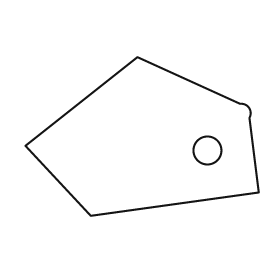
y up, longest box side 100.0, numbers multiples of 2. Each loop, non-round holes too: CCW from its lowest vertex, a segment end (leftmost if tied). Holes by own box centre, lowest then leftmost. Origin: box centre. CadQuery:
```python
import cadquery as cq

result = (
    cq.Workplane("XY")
    .moveTo(-22.0, -34.0)
    .lineTo(50.0, -24.0)
    .lineTo(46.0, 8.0)
    .threePointArc((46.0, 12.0), (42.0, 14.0))
    .lineTo(-2.0, 34.0)
    .lineTo(-50.0, -4.0)
    .close()
    .moveTo(28.0, -6.0)
    .circle(6.0)
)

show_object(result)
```